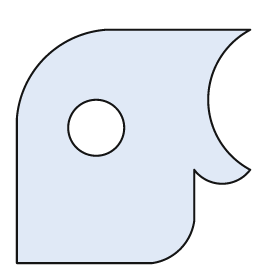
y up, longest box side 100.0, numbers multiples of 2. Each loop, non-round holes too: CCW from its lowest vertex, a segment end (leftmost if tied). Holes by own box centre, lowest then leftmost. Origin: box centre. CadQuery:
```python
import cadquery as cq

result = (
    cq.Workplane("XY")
    .moveTo(-50.0, -50.0)
    .lineTo(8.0, -50.0)
    .threePointArc((20.0, -44.0), (26.0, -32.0))
    .lineTo(26.0, -10.0)
    .threePointArc((38.0, -16.0), (50.0, -10.0))
    .threePointArc((32.0, 20.0), (50.0, 50.0))
    .lineTo(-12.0, 50.0)
    .threePointArc((-38.0, 38.0), (-50.0, 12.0))
    .close()
    .moveTo(-16.0, 8.0)
    .circle(12.0)
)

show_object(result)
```